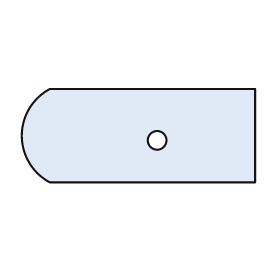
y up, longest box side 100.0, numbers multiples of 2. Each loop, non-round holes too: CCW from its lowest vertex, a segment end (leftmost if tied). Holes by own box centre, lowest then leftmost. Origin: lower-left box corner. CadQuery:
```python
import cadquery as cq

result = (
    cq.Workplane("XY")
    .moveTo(12.0, 0.0)
    .lineTo(100.0, 0.0)
    .lineTo(100.0, 40.0)
    .lineTo(12.0, 40.0)
    .threePointArc((0.0, 20.0), (12.0, 0.0))
    .close()
    .moveTo(58.0, 18.0)
    .circle(4.0)
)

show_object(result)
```